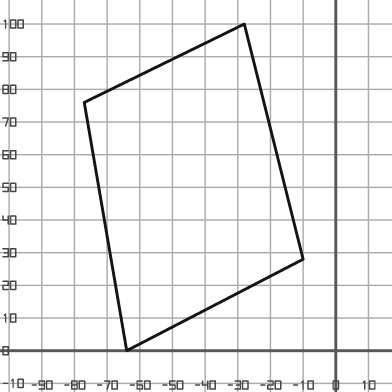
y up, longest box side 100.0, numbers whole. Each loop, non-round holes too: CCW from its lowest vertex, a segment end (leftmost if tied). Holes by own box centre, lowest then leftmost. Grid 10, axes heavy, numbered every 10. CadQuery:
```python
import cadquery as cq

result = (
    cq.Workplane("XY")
    .moveTo(-64.0, 0.0)
    .lineTo(-10.0, 28.0)
    .lineTo(-28.0, 100.0)
    .lineTo(-77.0, 76.0)
    .close()
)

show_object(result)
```